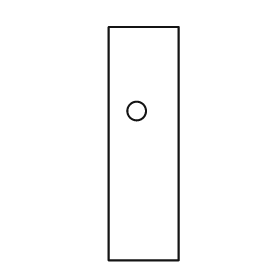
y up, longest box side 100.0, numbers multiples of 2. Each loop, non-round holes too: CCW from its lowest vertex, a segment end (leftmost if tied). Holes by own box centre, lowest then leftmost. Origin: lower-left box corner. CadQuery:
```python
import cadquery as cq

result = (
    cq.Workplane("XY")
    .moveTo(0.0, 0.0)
    .lineTo(30.0, 0.0)
    .lineTo(30.0, 100.0)
    .lineTo(0.0, 100.0)
    .close()
    .moveTo(12.0, 64.0)
    .circle(4.0)
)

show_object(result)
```